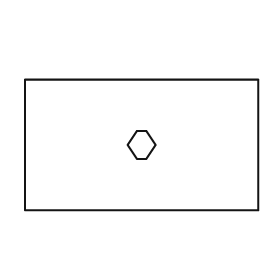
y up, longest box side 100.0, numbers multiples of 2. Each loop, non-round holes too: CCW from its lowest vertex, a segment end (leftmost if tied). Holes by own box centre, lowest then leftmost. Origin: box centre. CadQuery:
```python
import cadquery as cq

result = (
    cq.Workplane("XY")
    .moveTo(-50.0, -28.0)
    .lineTo(50.0, -28.0)
    .lineTo(50.0, 28.0)
    .lineTo(-50.0, 28.0)
    .close()
    .moveTo(-2.0, -6.0)
    .lineTo(2.0, -6.0)
    .lineTo(6.0, 0.0)
    .lineTo(2.0, 6.0)
    .lineTo(-2.0, 6.0)
    .lineTo(-6.0, 0.0)
    .close()
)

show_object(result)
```